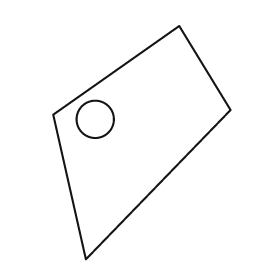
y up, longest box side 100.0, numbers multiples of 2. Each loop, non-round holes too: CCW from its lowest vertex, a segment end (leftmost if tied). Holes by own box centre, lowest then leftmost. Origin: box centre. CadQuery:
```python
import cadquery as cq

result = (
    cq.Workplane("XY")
    .moveTo(-24.0, -50.0)
    .lineTo(38.0, 14.0)
    .lineTo(16.0, 50.0)
    .lineTo(-38.0, 12.0)
    .close()
    .moveTo(-20.0, 10.0)
    .circle(8.0)
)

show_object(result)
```